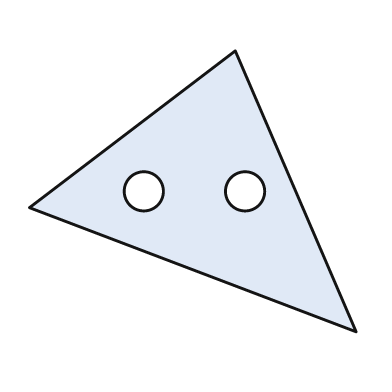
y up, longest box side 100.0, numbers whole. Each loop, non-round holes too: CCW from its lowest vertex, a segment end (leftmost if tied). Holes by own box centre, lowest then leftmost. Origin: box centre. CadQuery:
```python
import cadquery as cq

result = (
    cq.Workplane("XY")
    .moveTo(50.0, -43.0)
    .lineTo(13.0, 43.0)
    .lineTo(-50.0, -5.0)
    .close()
    .moveTo(-15.0, 0.0)
    .circle(6.0)
    .moveTo(16.0, 0.0)
    .circle(6.0)
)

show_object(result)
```